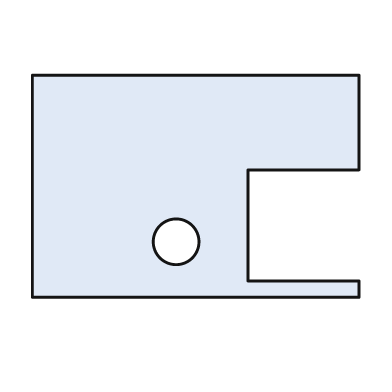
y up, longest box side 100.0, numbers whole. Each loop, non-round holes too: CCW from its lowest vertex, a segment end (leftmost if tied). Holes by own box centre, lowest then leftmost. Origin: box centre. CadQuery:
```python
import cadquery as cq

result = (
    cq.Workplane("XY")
    .moveTo(-50.0, -34.0)
    .lineTo(50.0, -34.0)
    .lineTo(50.0, -29.0)
    .lineTo(16.0, -29.0)
    .lineTo(16.0, 5.0)
    .lineTo(50.0, 5.0)
    .lineTo(50.0, 34.0)
    .lineTo(-50.0, 34.0)
    .close()
    .moveTo(-6.0, -17.0)
    .circle(7.0)
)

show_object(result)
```